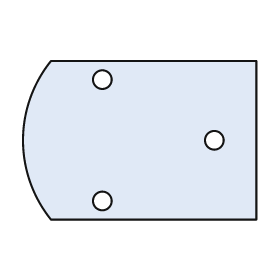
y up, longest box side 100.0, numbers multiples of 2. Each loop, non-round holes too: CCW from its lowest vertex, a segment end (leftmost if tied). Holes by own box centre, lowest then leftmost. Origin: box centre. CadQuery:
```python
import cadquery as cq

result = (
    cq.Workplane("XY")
    .moveTo(-38.0, -34.0)
    .lineTo(50.0, -34.0)
    .lineTo(50.0, 34.0)
    .lineTo(-38.0, 34.0)
    .threePointArc((-50.0, 0.0), (-38.0, -34.0))
    .close()
    .moveTo(-16.0, -26.0)
    .circle(4.0)
    .moveTo(32.0, 0.0)
    .circle(4.0)
    .moveTo(-16.0, 26.0)
    .circle(4.0)
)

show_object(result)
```